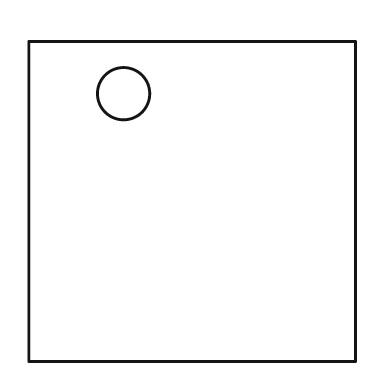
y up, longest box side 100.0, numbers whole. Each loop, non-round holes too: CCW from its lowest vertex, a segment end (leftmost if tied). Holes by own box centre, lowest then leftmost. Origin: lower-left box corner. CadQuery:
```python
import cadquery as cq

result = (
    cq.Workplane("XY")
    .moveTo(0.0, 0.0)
    .lineTo(100.0, 0.0)
    .lineTo(100.0, 98.0)
    .lineTo(0.0, 98.0)
    .close()
    .moveTo(29.0, 82.0)
    .circle(8.0)
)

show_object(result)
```